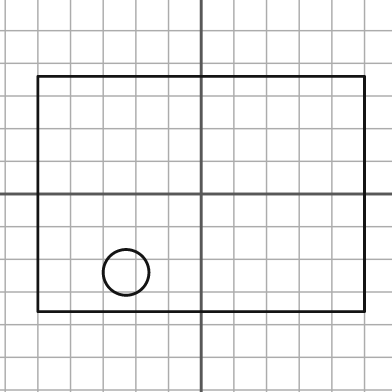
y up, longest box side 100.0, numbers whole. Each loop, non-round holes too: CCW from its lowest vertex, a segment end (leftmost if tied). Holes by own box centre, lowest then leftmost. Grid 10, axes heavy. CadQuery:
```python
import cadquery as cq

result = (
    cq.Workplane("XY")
    .moveTo(-50.0, -36.0)
    .lineTo(50.0, -36.0)
    .lineTo(50.0, 36.0)
    .lineTo(-50.0, 36.0)
    .close()
    .moveTo(-23.0, -24.0)
    .circle(7.0)
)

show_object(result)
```